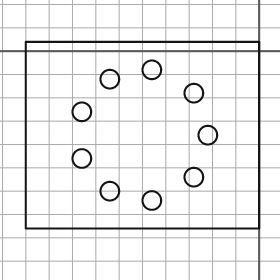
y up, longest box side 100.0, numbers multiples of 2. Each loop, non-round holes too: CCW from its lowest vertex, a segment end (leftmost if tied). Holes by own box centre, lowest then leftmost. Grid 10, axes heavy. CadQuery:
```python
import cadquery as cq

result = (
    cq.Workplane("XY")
    .moveTo(-100.0, -76.0)
    .lineTo(0.0, -76.0)
    .lineTo(0.0, 4.0)
    .lineTo(-100.0, 4.0)
    .close()
    .moveTo(-46.0, -64.0)
    .circle(4.0)
    .moveTo(-64.0, -60.0)
    .circle(4.0)
    .moveTo(-28.0, -54.0)
    .circle(4.0)
    .moveTo(-76.0, -46.0)
    .circle(4.0)
    .moveTo(-22.0, -36.0)
    .circle(4.0)
    .moveTo(-76.0, -26.0)
    .circle(4.0)
    .moveTo(-28.0, -18.0)
    .circle(4.0)
    .moveTo(-64.0, -12.0)
    .circle(4.0)
    .moveTo(-46.0, -8.0)
    .circle(4.0)
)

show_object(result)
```